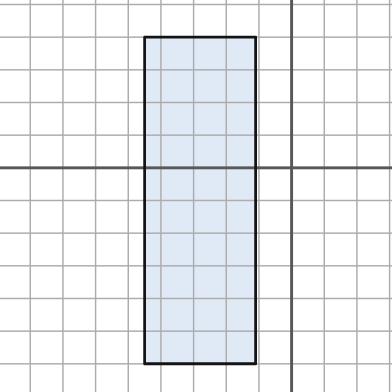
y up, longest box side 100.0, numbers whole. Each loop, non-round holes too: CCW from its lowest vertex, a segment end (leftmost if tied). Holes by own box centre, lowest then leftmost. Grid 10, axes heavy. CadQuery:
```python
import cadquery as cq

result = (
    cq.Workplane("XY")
    .moveTo(-45.0, -60.0)
    .lineTo(-11.0, -60.0)
    .lineTo(-11.0, 40.0)
    .lineTo(-45.0, 40.0)
    .close()
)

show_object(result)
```